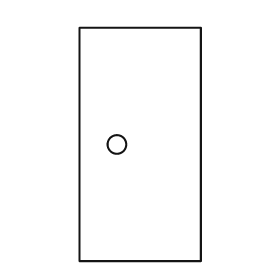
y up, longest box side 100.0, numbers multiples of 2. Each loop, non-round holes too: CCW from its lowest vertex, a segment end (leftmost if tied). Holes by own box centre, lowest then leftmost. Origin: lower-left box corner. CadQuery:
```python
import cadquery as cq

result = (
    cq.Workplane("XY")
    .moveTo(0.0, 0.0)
    .lineTo(52.0, 0.0)
    .lineTo(52.0, 100.0)
    .lineTo(0.0, 100.0)
    .close()
    .moveTo(16.0, 50.0)
    .circle(4.0)
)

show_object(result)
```